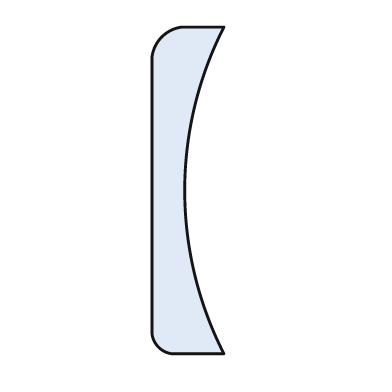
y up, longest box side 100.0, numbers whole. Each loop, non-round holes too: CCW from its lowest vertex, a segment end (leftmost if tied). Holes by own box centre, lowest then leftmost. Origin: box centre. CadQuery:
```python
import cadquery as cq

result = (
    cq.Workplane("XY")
    .moveTo(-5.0, -50.0)
    .lineTo(11.0, -50.0)
    .threePointArc((-1.0, 0.0), (11.0, 50.0))
    .lineTo(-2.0, 50.0)
    .threePointArc((-8.0, 47.0), (-11.0, 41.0))
    .lineTo(-11.0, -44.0)
    .threePointArc((-9.0, -48.0), (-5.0, -50.0))
    .close()
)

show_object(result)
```